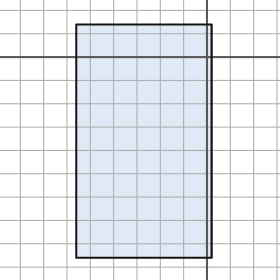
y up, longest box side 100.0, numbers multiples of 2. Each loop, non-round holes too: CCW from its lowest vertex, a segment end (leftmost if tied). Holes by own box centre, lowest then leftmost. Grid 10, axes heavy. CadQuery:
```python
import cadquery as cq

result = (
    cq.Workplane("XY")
    .moveTo(-56.0, -86.0)
    .lineTo(2.0, -86.0)
    .lineTo(2.0, 14.0)
    .lineTo(-56.0, 14.0)
    .close()
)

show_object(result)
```